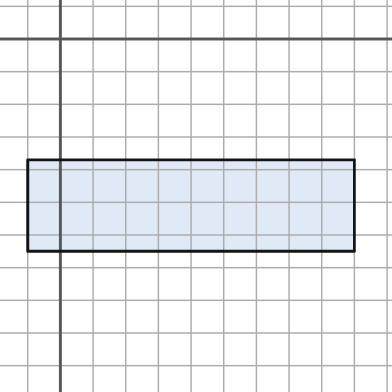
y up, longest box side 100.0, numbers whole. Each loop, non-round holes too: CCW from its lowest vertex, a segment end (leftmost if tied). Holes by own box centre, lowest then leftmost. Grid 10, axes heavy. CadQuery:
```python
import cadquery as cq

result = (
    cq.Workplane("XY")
    .moveTo(-10.0, -65.0)
    .lineTo(90.0, -65.0)
    .lineTo(90.0, -37.0)
    .lineTo(-10.0, -37.0)
    .close()
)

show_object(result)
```